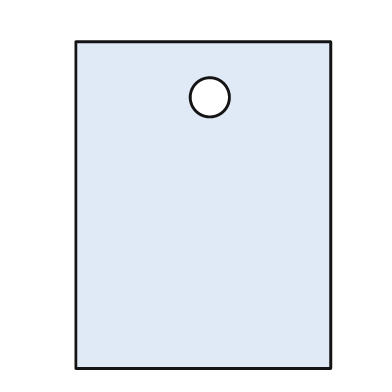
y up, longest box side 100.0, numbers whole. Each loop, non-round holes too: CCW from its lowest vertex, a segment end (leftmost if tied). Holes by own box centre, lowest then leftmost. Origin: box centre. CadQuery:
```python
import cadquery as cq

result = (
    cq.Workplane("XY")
    .moveTo(-39.0, -50.0)
    .lineTo(39.0, -50.0)
    .lineTo(39.0, 50.0)
    .lineTo(-39.0, 50.0)
    .close()
    .moveTo(2.0, 33.0)
    .circle(6.0)
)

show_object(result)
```